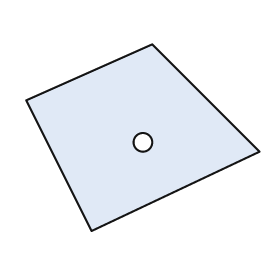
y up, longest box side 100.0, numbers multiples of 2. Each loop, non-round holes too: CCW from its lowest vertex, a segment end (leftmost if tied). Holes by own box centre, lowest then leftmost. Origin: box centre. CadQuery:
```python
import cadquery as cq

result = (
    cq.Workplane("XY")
    .moveTo(-22.0, -40.0)
    .lineTo(50.0, -6.0)
    .lineTo(4.0, 40.0)
    .lineTo(-50.0, 16.0)
    .close()
    .moveTo(0.0, -2.0)
    .circle(4.0)
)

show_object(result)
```